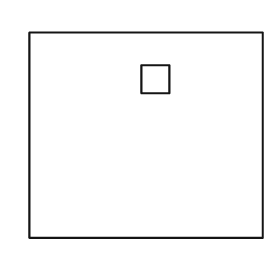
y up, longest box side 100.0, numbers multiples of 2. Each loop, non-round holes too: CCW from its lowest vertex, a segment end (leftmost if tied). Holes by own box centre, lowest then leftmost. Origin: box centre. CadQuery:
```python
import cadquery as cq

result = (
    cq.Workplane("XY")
    .moveTo(-50.0, -44.0)
    .lineTo(50.0, -44.0)
    .lineTo(50.0, 44.0)
    .lineTo(-50.0, 44.0)
    .close()
    .moveTo(-2.0, 18.0)
    .lineTo(10.0, 18.0)
    .lineTo(10.0, 30.0)
    .lineTo(-2.0, 30.0)
    .close()
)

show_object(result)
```